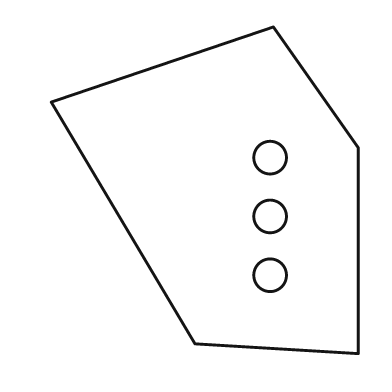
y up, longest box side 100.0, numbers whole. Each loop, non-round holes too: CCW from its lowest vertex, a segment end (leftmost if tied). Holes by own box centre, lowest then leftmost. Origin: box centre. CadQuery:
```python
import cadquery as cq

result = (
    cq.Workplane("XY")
    .moveTo(47.0, -50.0)
    .lineTo(47.0, 13.0)
    .lineTo(21.0, 50.0)
    .lineTo(-47.0, 27.0)
    .lineTo(-3.0, -47.0)
    .close()
    .moveTo(20.0, -26.0)
    .circle(5.0)
    .moveTo(20.0, -8.0)
    .circle(5.0)
    .moveTo(20.0, 10.0)
    .circle(5.0)
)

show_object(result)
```